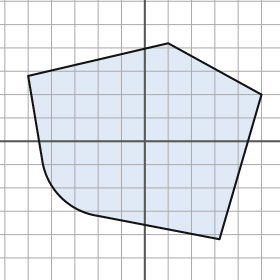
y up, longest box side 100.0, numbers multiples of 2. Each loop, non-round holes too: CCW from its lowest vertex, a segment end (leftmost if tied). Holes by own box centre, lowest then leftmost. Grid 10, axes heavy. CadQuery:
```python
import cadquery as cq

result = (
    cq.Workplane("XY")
    .moveTo(32.0, -42.0)
    .lineTo(50.0, 20.0)
    .lineTo(10.0, 42.0)
    .lineTo(-50.0, 28.0)
    .lineTo(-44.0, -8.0)
    .threePointArc((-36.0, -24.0), (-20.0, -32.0))
    .close()
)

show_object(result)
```